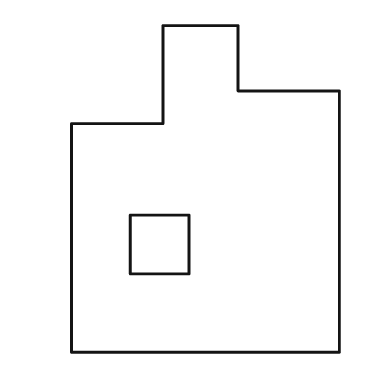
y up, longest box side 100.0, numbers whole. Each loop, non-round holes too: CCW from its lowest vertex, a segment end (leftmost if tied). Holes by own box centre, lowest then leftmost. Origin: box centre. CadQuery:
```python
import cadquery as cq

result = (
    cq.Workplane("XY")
    .moveTo(-41.0, -50.0)
    .lineTo(41.0, -50.0)
    .lineTo(41.0, 30.0)
    .lineTo(10.0, 30.0)
    .lineTo(10.0, 50.0)
    .lineTo(-13.0, 50.0)
    .lineTo(-13.0, 20.0)
    .lineTo(-41.0, 20.0)
    .close()
    .moveTo(-23.0, -26.0)
    .lineTo(-5.0, -26.0)
    .lineTo(-5.0, -8.0)
    .lineTo(-23.0, -8.0)
    .close()
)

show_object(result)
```